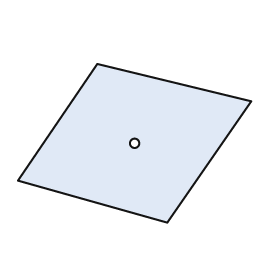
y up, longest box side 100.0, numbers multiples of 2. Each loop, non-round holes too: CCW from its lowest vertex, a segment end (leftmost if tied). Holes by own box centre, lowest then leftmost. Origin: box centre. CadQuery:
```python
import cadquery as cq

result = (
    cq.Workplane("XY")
    .moveTo(14.0, -34.0)
    .lineTo(50.0, 18.0)
    .lineTo(-16.0, 34.0)
    .lineTo(-50.0, -16.0)
    .close()
    .moveTo(0.0, 0.0)
    .circle(2.0)
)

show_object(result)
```